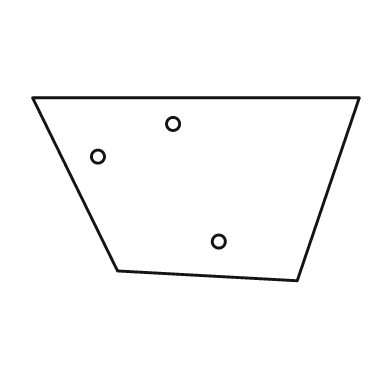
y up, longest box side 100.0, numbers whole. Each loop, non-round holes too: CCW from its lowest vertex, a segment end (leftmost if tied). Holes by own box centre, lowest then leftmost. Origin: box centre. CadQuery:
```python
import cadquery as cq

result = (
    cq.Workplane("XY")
    .moveTo(31.0, -28.0)
    .lineTo(50.0, 28.0)
    .lineTo(-50.0, 28.0)
    .lineTo(-24.0, -25.0)
    .close()
    .moveTo(7.0, -16.0)
    .circle(2.0)
    .moveTo(-30.0, 10.0)
    .circle(2.0)
    .moveTo(-7.0, 20.0)
    .circle(2.0)
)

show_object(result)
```